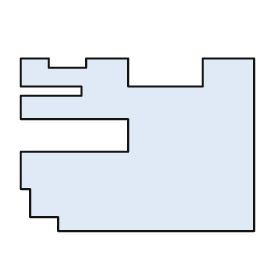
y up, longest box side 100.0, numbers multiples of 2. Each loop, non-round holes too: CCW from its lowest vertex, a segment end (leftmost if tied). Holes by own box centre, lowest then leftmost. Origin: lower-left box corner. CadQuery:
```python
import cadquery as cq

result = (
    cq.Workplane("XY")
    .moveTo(16.0, 0.0)
    .lineTo(100.0, 0.0)
    .lineTo(100.0, 74.0)
    .lineTo(78.0, 74.0)
    .lineTo(78.0, 62.0)
    .lineTo(46.0, 62.0)
    .lineTo(46.0, 74.0)
    .lineTo(28.0, 74.0)
    .lineTo(28.0, 70.0)
    .lineTo(12.0, 70.0)
    .lineTo(12.0, 74.0)
    .lineTo(0.0, 74.0)
    .lineTo(0.0, 62.0)
    .lineTo(26.0, 62.0)
    .lineTo(26.0, 58.0)
    .lineTo(0.0, 58.0)
    .lineTo(0.0, 48.0)
    .lineTo(46.0, 48.0)
    .lineTo(46.0, 34.0)
    .lineTo(0.0, 34.0)
    .lineTo(0.0, 18.0)
    .lineTo(4.0, 18.0)
    .lineTo(4.0, 6.0)
    .lineTo(16.0, 6.0)
    .close()
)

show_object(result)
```